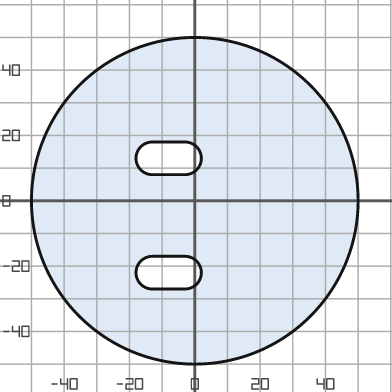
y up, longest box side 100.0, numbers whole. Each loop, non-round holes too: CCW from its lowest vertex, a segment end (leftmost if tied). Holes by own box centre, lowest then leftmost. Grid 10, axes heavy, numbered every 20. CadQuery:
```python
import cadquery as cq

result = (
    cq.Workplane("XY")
    .moveTo(0.0, 0.0)
    .circle(50.0)
    .moveTo(-13.0, -27.0)
    .lineTo(-3.0, -27.0)
    .threePointArc((2.0, -22.0), (-3.0, -17.0))
    .lineTo(-13.0, -17.0)
    .threePointArc((-18.0, -22.0), (-13.0, -27.0))
    .close()
    .moveTo(-13.0, 8.0)
    .lineTo(-3.0, 8.0)
    .threePointArc((2.0, 13.0), (-3.0, 18.0))
    .lineTo(-13.0, 18.0)
    .threePointArc((-18.0, 13.0), (-13.0, 8.0))
    .close()
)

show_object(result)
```